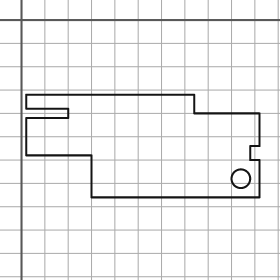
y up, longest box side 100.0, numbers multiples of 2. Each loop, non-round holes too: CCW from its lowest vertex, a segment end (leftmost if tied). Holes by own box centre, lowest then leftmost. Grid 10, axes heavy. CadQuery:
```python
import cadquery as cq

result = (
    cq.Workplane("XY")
    .moveTo(30.0, -76.0)
    .lineTo(102.0, -76.0)
    .lineTo(102.0, -60.0)
    .lineTo(98.0, -60.0)
    .lineTo(98.0, -54.0)
    .lineTo(102.0, -54.0)
    .lineTo(102.0, -40.0)
    .lineTo(74.0, -40.0)
    .lineTo(74.0, -32.0)
    .lineTo(2.0, -32.0)
    .lineTo(2.0, -38.0)
    .lineTo(20.0, -38.0)
    .lineTo(20.0, -42.0)
    .lineTo(2.0, -42.0)
    .lineTo(2.0, -58.0)
    .lineTo(30.0, -58.0)
    .close()
    .moveTo(94.0, -68.0)
    .circle(4.0)
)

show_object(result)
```